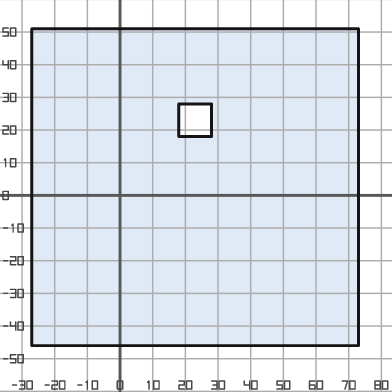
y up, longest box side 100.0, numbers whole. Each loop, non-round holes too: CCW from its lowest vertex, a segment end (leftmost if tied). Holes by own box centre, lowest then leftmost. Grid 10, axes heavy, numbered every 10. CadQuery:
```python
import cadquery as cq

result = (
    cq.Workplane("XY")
    .moveTo(-27.0, -46.0)
    .lineTo(73.0, -46.0)
    .lineTo(73.0, 51.0)
    .lineTo(-27.0, 51.0)
    .close()
    .moveTo(18.0, 18.0)
    .lineTo(28.0, 18.0)
    .lineTo(28.0, 28.0)
    .lineTo(18.0, 28.0)
    .close()
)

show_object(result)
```